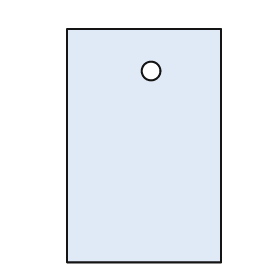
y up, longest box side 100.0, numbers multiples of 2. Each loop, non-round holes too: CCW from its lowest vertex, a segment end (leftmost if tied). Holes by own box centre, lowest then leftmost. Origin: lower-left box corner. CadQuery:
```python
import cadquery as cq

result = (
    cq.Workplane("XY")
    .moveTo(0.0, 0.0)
    .lineTo(66.0, 0.0)
    .lineTo(66.0, 100.0)
    .lineTo(0.0, 100.0)
    .close()
    .moveTo(36.0, 82.0)
    .circle(4.0)
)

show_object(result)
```